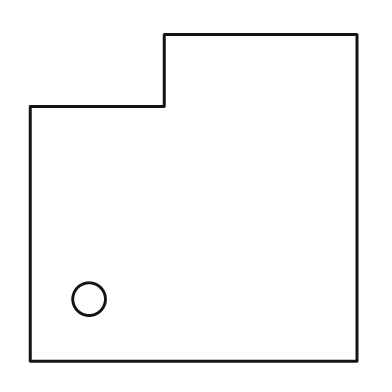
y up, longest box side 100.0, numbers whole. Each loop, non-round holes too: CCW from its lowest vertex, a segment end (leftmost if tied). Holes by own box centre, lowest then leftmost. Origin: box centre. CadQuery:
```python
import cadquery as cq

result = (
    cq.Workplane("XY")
    .moveTo(-50.0, -50.0)
    .lineTo(50.0, -50.0)
    .lineTo(50.0, 50.0)
    .lineTo(-9.0, 50.0)
    .lineTo(-9.0, 28.0)
    .lineTo(-50.0, 28.0)
    .close()
    .moveTo(-32.0, -31.0)
    .circle(5.0)
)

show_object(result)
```